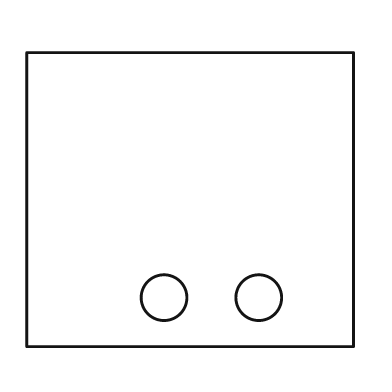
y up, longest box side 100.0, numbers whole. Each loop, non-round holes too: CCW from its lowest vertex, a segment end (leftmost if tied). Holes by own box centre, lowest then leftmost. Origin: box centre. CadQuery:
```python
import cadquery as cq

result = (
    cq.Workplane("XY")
    .moveTo(-50.0, -45.0)
    .lineTo(50.0, -45.0)
    .lineTo(50.0, 45.0)
    .lineTo(-50.0, 45.0)
    .close()
    .moveTo(-8.0, -30.0)
    .circle(7.0)
    .moveTo(21.0, -30.0)
    .circle(7.0)
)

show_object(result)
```